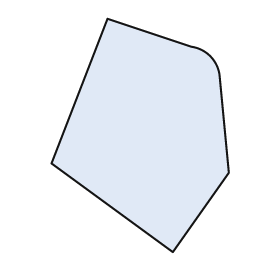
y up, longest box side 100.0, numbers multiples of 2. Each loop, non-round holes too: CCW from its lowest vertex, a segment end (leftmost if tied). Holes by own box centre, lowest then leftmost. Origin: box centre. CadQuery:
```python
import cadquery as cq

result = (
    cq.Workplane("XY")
    .moveTo(14.0, -50.0)
    .lineTo(38.0, -16.0)
    .lineTo(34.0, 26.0)
    .threePointArc((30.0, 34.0), (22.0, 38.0))
    .lineTo(-14.0, 50.0)
    .lineTo(-38.0, -12.0)
    .close()
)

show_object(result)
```